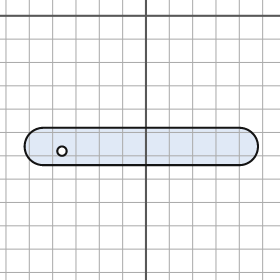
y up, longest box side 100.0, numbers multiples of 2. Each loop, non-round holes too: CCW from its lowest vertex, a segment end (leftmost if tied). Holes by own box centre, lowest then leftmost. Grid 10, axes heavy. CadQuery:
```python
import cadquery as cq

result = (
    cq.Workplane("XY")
    .moveTo(-44.0, -64.0)
    .lineTo(40.0, -64.0)
    .threePointArc((48.0, -56.0), (40.0, -48.0))
    .lineTo(-44.0, -48.0)
    .threePointArc((-52.0, -56.0), (-44.0, -64.0))
    .close()
    .moveTo(-36.0, -58.0)
    .circle(2.0)
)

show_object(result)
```